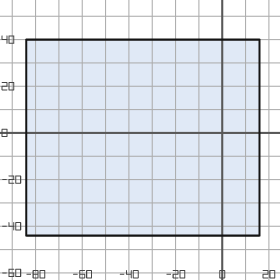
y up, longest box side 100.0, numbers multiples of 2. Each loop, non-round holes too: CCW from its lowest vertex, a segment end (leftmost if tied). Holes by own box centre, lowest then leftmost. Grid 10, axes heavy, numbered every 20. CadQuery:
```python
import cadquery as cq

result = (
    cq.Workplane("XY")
    .moveTo(-84.0, -44.0)
    .lineTo(16.0, -44.0)
    .lineTo(16.0, 40.0)
    .lineTo(-84.0, 40.0)
    .close()
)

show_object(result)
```